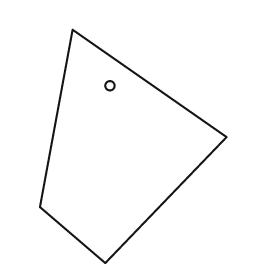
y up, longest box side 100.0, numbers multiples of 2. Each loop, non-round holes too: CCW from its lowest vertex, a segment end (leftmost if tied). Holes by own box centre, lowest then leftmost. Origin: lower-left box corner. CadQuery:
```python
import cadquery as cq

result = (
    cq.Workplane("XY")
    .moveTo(28.0, 0.0)
    .lineTo(80.0, 54.0)
    .lineTo(14.0, 100.0)
    .lineTo(0.0, 24.0)
    .close()
    .moveTo(30.0, 76.0)
    .circle(2.0)
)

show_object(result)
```